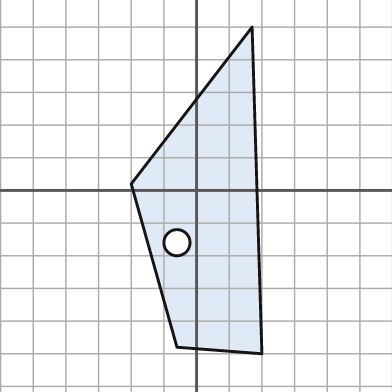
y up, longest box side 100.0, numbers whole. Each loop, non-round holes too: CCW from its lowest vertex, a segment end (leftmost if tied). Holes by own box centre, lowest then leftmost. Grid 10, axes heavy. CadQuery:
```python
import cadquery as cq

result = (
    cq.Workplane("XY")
    .moveTo(20.0, -50.0)
    .lineTo(17.0, 50.0)
    .lineTo(-20.0, 2.0)
    .lineTo(-6.0, -48.0)
    .close()
    .moveTo(-6.0, -16.0)
    .circle(4.0)
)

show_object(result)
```